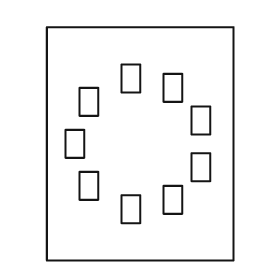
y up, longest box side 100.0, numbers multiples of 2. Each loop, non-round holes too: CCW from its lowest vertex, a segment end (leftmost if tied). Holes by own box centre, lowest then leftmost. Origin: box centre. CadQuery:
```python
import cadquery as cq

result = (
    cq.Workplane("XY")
    .moveTo(-40.0, -50.0)
    .lineTo(40.0, -50.0)
    .lineTo(40.0, 50.0)
    .lineTo(-40.0, 50.0)
    .close()
    .moveTo(-8.0, -34.0)
    .lineTo(0.0, -34.0)
    .lineTo(0.0, -22.0)
    .lineTo(-8.0, -22.0)
    .close()
    .moveTo(10.0, -30.0)
    .lineTo(18.0, -30.0)
    .lineTo(18.0, -18.0)
    .lineTo(10.0, -18.0)
    .close()
    .moveTo(-26.0, -24.0)
    .lineTo(-18.0, -24.0)
    .lineTo(-18.0, -12.0)
    .lineTo(-26.0, -12.0)
    .close()
    .moveTo(22.0, -16.0)
    .lineTo(30.0, -16.0)
    .lineTo(30.0, -4.0)
    .lineTo(22.0, -4.0)
    .close()
    .moveTo(-32.0, -6.0)
    .lineTo(-24.0, -6.0)
    .lineTo(-24.0, 6.0)
    .lineTo(-32.0, 6.0)
    .close()
    .moveTo(22.0, 4.0)
    .lineTo(30.0, 4.0)
    .lineTo(30.0, 16.0)
    .lineTo(22.0, 16.0)
    .close()
    .moveTo(-26.0, 12.0)
    .lineTo(-18.0, 12.0)
    .lineTo(-18.0, 24.0)
    .lineTo(-26.0, 24.0)
    .close()
    .moveTo(10.0, 18.0)
    .lineTo(18.0, 18.0)
    .lineTo(18.0, 30.0)
    .lineTo(10.0, 30.0)
    .close()
    .moveTo(-8.0, 22.0)
    .lineTo(0.0, 22.0)
    .lineTo(0.0, 34.0)
    .lineTo(-8.0, 34.0)
    .close()
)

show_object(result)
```